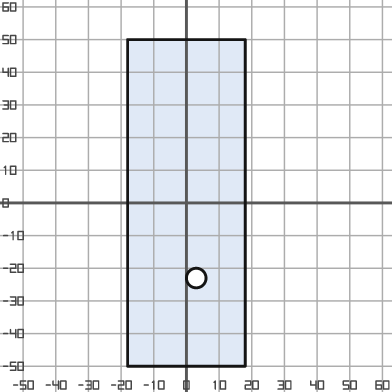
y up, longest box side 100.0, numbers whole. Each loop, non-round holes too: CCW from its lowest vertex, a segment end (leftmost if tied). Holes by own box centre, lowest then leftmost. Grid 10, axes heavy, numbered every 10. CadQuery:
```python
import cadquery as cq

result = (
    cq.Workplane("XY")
    .moveTo(-18.0, -50.0)
    .lineTo(18.0, -50.0)
    .lineTo(18.0, 50.0)
    .lineTo(-18.0, 50.0)
    .close()
    .moveTo(3.0, -23.0)
    .circle(3.0)
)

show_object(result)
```